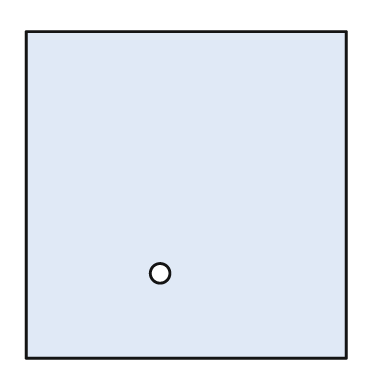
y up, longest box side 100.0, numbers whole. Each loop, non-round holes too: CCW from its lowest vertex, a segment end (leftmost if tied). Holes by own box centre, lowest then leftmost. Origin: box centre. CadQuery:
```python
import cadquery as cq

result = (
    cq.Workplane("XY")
    .moveTo(-49.0, -50.0)
    .lineTo(49.0, -50.0)
    .lineTo(49.0, 50.0)
    .lineTo(-49.0, 50.0)
    .close()
    .moveTo(-8.0, -24.0)
    .circle(3.0)
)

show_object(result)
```